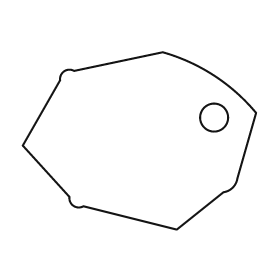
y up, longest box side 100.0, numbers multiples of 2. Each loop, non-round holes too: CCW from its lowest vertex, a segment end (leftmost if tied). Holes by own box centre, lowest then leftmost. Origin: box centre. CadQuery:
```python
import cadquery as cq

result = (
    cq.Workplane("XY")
    .moveTo(16.0, -38.0)
    .lineTo(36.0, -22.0)
    .threePointArc((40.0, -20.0), (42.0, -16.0))
    .lineTo(50.0, 12.0)
    .threePointArc((32.0, 28.0), (10.0, 38.0))
    .lineTo(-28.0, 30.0)
    .threePointArc((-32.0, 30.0), (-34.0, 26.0))
    .lineTo(-50.0, -2.0)
    .lineTo(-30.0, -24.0)
    .threePointArc((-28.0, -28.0), (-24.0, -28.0))
    .close()
    .moveTo(32.0, 10.0)
    .circle(6.0)
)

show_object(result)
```